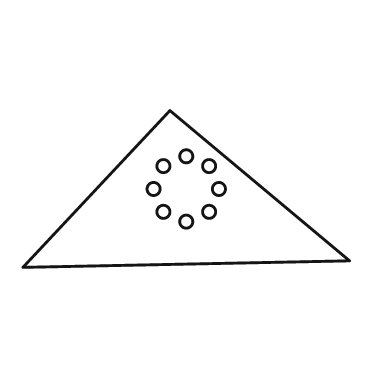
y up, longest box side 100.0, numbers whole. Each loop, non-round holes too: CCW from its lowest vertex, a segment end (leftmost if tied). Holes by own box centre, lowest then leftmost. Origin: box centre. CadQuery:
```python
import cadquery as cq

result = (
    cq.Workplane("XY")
    .moveTo(-50.0, -24.0)
    .lineTo(50.0, -22.0)
    .lineTo(-5.0, 24.0)
    .close()
    .moveTo(0.0, -10.0)
    .circle(2.0)
    .moveTo(-7.0, -7.0)
    .circle(2.0)
    .moveTo(7.0, -7.0)
    .circle(2.0)
    .moveTo(-10.0, 0.0)
    .circle(2.0)
    .moveTo(10.0, 0.0)
    .circle(2.0)
    .moveTo(-7.0, 7.0)
    .circle(2.0)
    .moveTo(7.0, 7.0)
    .circle(2.0)
    .moveTo(0.0, 10.0)
    .circle(2.0)
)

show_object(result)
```